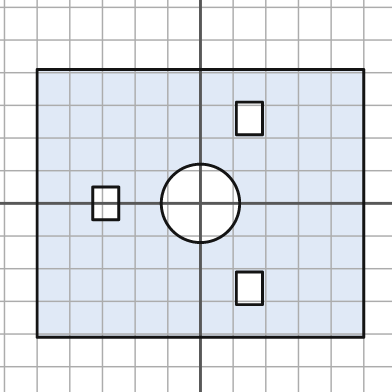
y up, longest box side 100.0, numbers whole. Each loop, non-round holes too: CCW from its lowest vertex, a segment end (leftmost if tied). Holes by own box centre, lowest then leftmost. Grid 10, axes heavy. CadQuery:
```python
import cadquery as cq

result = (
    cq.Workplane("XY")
    .moveTo(-50.0, -41.0)
    .lineTo(50.0, -41.0)
    .lineTo(50.0, 41.0)
    .lineTo(-50.0, 41.0)
    .close()
    .moveTo(11.0, -31.0)
    .lineTo(19.0, -31.0)
    .lineTo(19.0, -21.0)
    .lineTo(11.0, -21.0)
    .close()
    .moveTo(-33.0, -5.0)
    .lineTo(-25.0, -5.0)
    .lineTo(-25.0, 5.0)
    .lineTo(-33.0, 5.0)
    .close()
    .moveTo(0.0, 0.0)
    .circle(12.0)
    .moveTo(11.0, 21.0)
    .lineTo(19.0, 21.0)
    .lineTo(19.0, 31.0)
    .lineTo(11.0, 31.0)
    .close()
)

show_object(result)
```